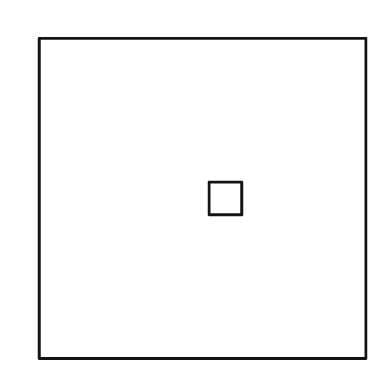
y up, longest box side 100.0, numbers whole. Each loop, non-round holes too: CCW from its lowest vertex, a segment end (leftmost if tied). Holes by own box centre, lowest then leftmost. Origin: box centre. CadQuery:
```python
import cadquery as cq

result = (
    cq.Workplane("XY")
    .moveTo(-50.0, -49.0)
    .lineTo(50.0, -49.0)
    .lineTo(50.0, 49.0)
    .lineTo(-50.0, 49.0)
    .close()
    .moveTo(2.0, -5.0)
    .lineTo(12.0, -5.0)
    .lineTo(12.0, 5.0)
    .lineTo(2.0, 5.0)
    .close()
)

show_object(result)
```